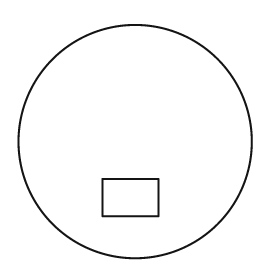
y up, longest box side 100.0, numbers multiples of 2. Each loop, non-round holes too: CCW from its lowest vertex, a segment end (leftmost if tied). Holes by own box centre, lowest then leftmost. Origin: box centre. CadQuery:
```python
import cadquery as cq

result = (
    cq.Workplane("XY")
    .moveTo(0.0, 0.0)
    .circle(50.0)
    .moveTo(-14.0, -32.0)
    .lineTo(10.0, -32.0)
    .lineTo(10.0, -16.0)
    .lineTo(-14.0, -16.0)
    .close()
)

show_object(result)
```